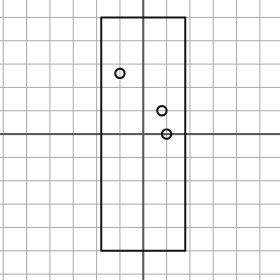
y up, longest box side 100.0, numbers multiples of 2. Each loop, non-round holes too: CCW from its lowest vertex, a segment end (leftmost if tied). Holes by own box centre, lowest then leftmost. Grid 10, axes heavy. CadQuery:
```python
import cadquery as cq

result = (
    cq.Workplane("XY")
    .moveTo(-18.0, -50.0)
    .lineTo(18.0, -50.0)
    .lineTo(18.0, 50.0)
    .lineTo(-18.0, 50.0)
    .close()
    .moveTo(10.0, 0.0)
    .circle(2.0)
    .moveTo(8.0, 10.0)
    .circle(2.0)
    .moveTo(-10.0, 26.0)
    .circle(2.0)
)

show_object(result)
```